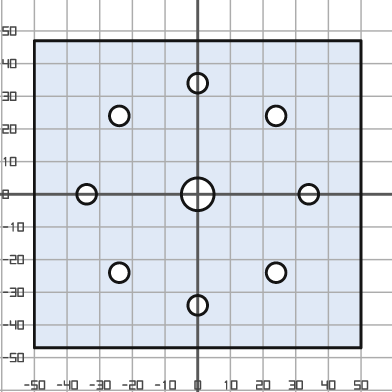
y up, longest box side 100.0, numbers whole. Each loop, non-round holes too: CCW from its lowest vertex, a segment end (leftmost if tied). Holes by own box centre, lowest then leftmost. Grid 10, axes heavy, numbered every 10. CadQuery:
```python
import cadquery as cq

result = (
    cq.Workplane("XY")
    .moveTo(-50.0, -47.0)
    .lineTo(50.0, -47.0)
    .lineTo(50.0, 47.0)
    .lineTo(-50.0, 47.0)
    .close()
    .moveTo(0.0, -34.0)
    .circle(3.0)
    .moveTo(-24.0, -24.0)
    .circle(3.0)
    .moveTo(24.0, -24.0)
    .circle(3.0)
    .moveTo(-34.0, 0.0)
    .circle(3.0)
    .moveTo(0.0, 0.0)
    .circle(5.0)
    .moveTo(34.0, 0.0)
    .circle(3.0)
    .moveTo(-24.0, 24.0)
    .circle(3.0)
    .moveTo(24.0, 24.0)
    .circle(3.0)
    .moveTo(0.0, 34.0)
    .circle(3.0)
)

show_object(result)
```